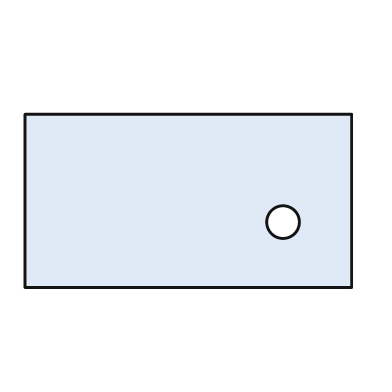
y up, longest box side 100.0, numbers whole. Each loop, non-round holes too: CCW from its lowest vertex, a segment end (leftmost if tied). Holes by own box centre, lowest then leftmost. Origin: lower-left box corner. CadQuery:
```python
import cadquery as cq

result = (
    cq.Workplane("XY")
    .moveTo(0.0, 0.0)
    .lineTo(100.0, 0.0)
    .lineTo(100.0, 53.0)
    .lineTo(0.0, 53.0)
    .close()
    .moveTo(79.0, 20.0)
    .circle(5.0)
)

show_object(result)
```